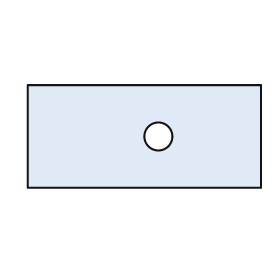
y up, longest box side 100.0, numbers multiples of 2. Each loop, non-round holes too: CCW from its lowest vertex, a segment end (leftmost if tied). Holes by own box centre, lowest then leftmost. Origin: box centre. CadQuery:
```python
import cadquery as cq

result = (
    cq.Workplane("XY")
    .moveTo(-50.0, -22.0)
    .lineTo(50.0, -22.0)
    .lineTo(50.0, 22.0)
    .lineTo(-50.0, 22.0)
    .close()
    .moveTo(6.0, 0.0)
    .circle(6.0)
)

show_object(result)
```